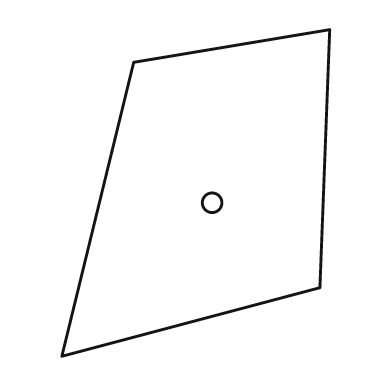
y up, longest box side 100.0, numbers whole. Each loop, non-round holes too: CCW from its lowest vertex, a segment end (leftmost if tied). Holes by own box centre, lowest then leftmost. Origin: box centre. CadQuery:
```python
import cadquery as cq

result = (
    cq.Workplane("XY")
    .moveTo(-41.0, -50.0)
    .lineTo(38.0, -29.0)
    .lineTo(41.0, 50.0)
    .lineTo(-19.0, 40.0)
    .close()
    .moveTo(5.0, -3.0)
    .circle(3.0)
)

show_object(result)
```